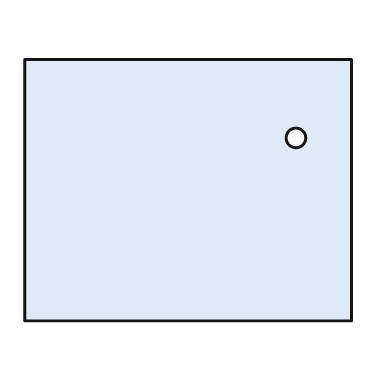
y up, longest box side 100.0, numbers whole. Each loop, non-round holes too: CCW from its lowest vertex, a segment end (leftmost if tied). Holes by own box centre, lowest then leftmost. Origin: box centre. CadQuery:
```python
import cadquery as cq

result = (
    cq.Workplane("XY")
    .moveTo(-50.0, -40.0)
    .lineTo(50.0, -40.0)
    .lineTo(50.0, 40.0)
    .lineTo(-50.0, 40.0)
    .close()
    .moveTo(33.0, 16.0)
    .circle(3.0)
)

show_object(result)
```